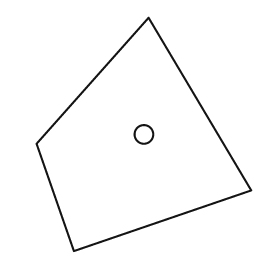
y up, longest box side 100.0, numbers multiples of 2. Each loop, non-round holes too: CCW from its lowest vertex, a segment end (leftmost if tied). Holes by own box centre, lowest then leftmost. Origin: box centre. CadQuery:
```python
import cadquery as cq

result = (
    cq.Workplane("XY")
    .moveTo(-30.0, -50.0)
    .lineTo(46.0, -24.0)
    .lineTo(2.0, 50.0)
    .lineTo(-46.0, -4.0)
    .close()
    .moveTo(0.0, 0.0)
    .circle(4.0)
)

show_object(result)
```